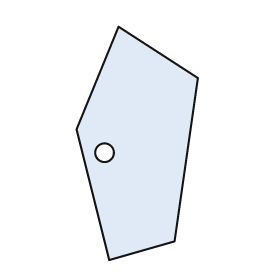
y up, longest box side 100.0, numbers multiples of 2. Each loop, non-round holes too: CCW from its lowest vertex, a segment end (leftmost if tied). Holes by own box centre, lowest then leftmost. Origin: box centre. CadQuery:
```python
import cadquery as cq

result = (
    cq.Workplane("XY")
    .moveTo(-12.0, -50.0)
    .lineTo(16.0, -42.0)
    .lineTo(26.0, 28.0)
    .lineTo(-8.0, 50.0)
    .lineTo(-26.0, 6.0)
    .close()
    .moveTo(-14.0, -4.0)
    .circle(4.0)
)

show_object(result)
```